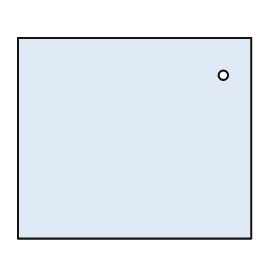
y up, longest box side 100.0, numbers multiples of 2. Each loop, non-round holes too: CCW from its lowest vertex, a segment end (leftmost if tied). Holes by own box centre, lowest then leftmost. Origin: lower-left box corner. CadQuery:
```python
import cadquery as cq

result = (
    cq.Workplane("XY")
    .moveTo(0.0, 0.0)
    .lineTo(100.0, 0.0)
    .lineTo(100.0, 86.0)
    .lineTo(0.0, 86.0)
    .close()
    .moveTo(88.0, 70.0)
    .circle(2.0)
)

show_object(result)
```